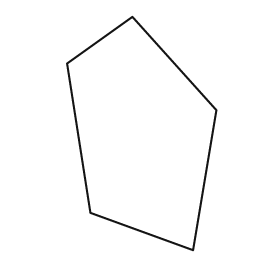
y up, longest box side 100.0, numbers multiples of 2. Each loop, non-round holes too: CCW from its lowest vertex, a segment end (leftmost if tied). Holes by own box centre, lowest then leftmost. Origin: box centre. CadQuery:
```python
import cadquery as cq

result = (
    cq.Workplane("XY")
    .moveTo(22.0, -50.0)
    .lineTo(32.0, 10.0)
    .lineTo(-4.0, 50.0)
    .lineTo(-32.0, 30.0)
    .lineTo(-22.0, -34.0)
    .close()
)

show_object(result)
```